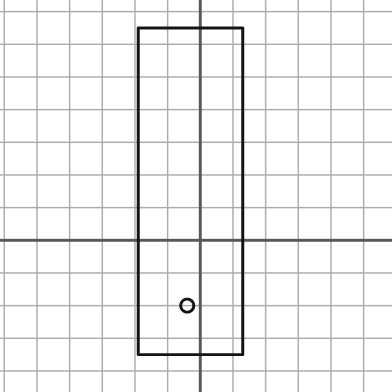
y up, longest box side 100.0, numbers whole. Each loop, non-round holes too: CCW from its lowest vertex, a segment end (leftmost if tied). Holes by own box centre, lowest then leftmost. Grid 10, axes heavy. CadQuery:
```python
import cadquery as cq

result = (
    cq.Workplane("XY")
    .moveTo(-19.0, -35.0)
    .lineTo(13.0, -35.0)
    .lineTo(13.0, 65.0)
    .lineTo(-19.0, 65.0)
    .close()
    .moveTo(-4.0, -20.0)
    .circle(2.0)
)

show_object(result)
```